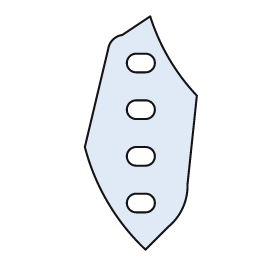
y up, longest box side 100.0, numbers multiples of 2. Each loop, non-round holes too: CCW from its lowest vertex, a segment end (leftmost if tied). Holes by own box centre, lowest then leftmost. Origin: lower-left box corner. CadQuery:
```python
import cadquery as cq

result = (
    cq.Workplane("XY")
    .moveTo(26.0, 0.0)
    .lineTo(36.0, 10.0)
    .threePointArc((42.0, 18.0), (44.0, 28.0))
    .lineTo(48.0, 66.0)
    .threePointArc((36.0, 82.0), (28.0, 100.0))
    .lineTo(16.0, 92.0)
    .threePointArc((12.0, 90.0), (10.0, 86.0))
    .lineTo(0.0, 44.0)
    .threePointArc((10.0, 20.0), (26.0, 0.0))
    .close()
    .moveTo(22.0, 16.0)
    .lineTo(26.0, 16.0)
    .threePointArc((30.0, 20.0), (26.0, 24.0))
    .lineTo(22.0, 24.0)
    .threePointArc((18.0, 20.0), (22.0, 16.0))
    .close()
    .moveTo(22.0, 36.0)
    .lineTo(26.0, 36.0)
    .threePointArc((30.0, 40.0), (26.0, 44.0))
    .lineTo(22.0, 44.0)
    .threePointArc((18.0, 40.0), (22.0, 36.0))
    .close()
    .moveTo(22.0, 56.0)
    .lineTo(26.0, 56.0)
    .threePointArc((30.0, 60.0), (26.0, 64.0))
    .lineTo(22.0, 64.0)
    .threePointArc((18.0, 60.0), (22.0, 56.0))
    .close()
    .moveTo(22.0, 76.0)
    .lineTo(26.0, 76.0)
    .threePointArc((30.0, 80.0), (26.0, 84.0))
    .lineTo(22.0, 84.0)
    .threePointArc((18.0, 80.0), (22.0, 76.0))
    .close()
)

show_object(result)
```